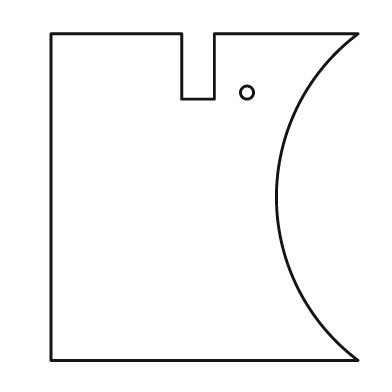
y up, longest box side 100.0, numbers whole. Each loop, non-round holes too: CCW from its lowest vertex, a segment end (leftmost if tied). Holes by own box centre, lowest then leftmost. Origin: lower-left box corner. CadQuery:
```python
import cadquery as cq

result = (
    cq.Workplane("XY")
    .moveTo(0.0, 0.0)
    .lineTo(94.0, 0.0)
    .threePointArc((69.0, 50.0), (94.0, 100.0))
    .lineTo(50.0, 100.0)
    .lineTo(50.0, 80.0)
    .lineTo(40.0, 80.0)
    .lineTo(40.0, 100.0)
    .lineTo(0.0, 100.0)
    .close()
    .moveTo(60.0, 82.0)
    .circle(2.0)
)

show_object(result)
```